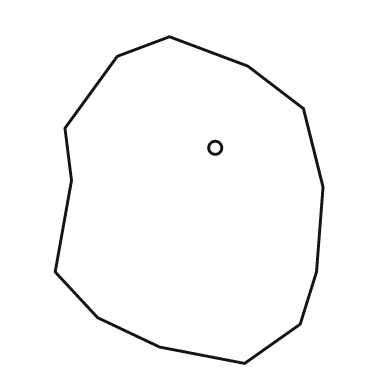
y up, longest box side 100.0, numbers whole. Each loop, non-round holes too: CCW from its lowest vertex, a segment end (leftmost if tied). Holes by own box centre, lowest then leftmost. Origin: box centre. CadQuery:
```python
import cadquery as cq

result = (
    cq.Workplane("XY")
    .moveTo(17.0, -50.0)
    .lineTo(34.0, -38.0)
    .lineTo(39.0, -22.0)
    .lineTo(41.0, 4.0)
    .lineTo(35.0, 28.0)
    .lineTo(18.0, 41.0)
    .lineTo(-6.0, 50.0)
    .lineTo(-22.0, 44.0)
    .lineTo(-38.0, 22.0)
    .lineTo(-36.0, 6.0)
    .lineTo(-41.0, -22.0)
    .lineTo(-28.0, -36.0)
    .lineTo(-9.0, -45.0)
    .close()
    .moveTo(8.0, 16.0)
    .circle(2.0)
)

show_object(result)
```